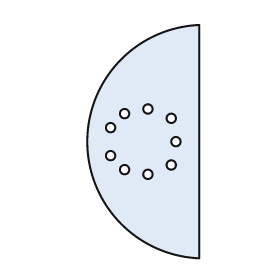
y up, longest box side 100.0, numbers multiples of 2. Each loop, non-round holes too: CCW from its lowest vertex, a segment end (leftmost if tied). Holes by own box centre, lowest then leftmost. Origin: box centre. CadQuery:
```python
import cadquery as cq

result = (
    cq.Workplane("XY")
    .moveTo(24.0, -50.0)
    .lineTo(24.0, 50.0)
    .threePointArc((-24.0, 0.0), (24.0, -50.0))
    .close()
    .moveTo(2.0, -14.0)
    .circle(2.0)
    .moveTo(-8.0, -12.0)
    .circle(2.0)
    .moveTo(12.0, -10.0)
    .circle(2.0)
    .moveTo(-14.0, -6.0)
    .circle(2.0)
    .moveTo(14.0, 0.0)
    .circle(2.0)
    .moveTo(-14.0, 6.0)
    .circle(2.0)
    .moveTo(12.0, 10.0)
    .circle(2.0)
    .moveTo(-8.0, 12.0)
    .circle(2.0)
    .moveTo(2.0, 14.0)
    .circle(2.0)
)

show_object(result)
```